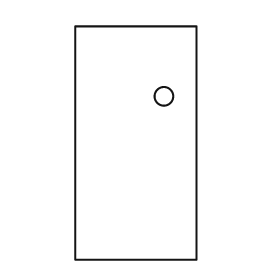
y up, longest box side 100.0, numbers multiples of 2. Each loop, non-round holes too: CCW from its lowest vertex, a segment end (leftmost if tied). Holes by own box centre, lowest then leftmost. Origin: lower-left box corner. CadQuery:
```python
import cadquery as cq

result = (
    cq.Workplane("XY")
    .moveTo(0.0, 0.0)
    .lineTo(52.0, 0.0)
    .lineTo(52.0, 100.0)
    .lineTo(0.0, 100.0)
    .close()
    .moveTo(38.0, 70.0)
    .circle(4.0)
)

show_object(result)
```